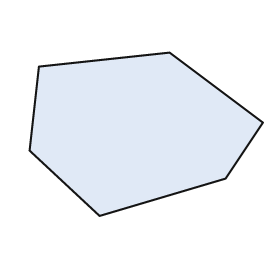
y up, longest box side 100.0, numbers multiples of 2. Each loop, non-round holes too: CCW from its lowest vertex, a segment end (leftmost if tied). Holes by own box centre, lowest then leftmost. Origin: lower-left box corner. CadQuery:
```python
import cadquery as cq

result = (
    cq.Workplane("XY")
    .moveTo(30.0, 0.0)
    .lineTo(84.0, 16.0)
    .lineTo(100.0, 40.0)
    .lineTo(60.0, 70.0)
    .lineTo(4.0, 64.0)
    .lineTo(0.0, 28.0)
    .close()
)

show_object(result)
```